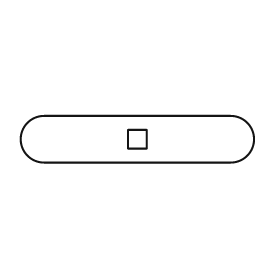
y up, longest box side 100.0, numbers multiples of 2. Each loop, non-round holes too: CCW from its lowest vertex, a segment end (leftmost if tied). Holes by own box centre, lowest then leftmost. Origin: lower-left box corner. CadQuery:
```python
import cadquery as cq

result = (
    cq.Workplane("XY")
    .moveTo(10.0, 0.0)
    .lineTo(90.0, 0.0)
    .threePointArc((100.0, 10.0), (90.0, 20.0))
    .lineTo(10.0, 20.0)
    .threePointArc((0.0, 10.0), (10.0, 0.0))
    .close()
    .moveTo(46.0, 6.0)
    .lineTo(54.0, 6.0)
    .lineTo(54.0, 14.0)
    .lineTo(46.0, 14.0)
    .close()
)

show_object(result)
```